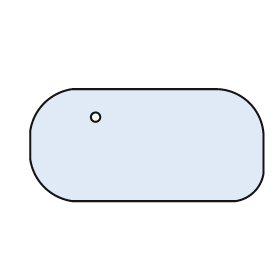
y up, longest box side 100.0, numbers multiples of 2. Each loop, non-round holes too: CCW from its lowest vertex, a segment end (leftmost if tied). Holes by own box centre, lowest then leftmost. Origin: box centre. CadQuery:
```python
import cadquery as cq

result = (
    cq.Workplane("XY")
    .moveTo(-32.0, -24.0)
    .lineTo(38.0, -24.0)
    .threePointArc((46.0, -20.0), (50.0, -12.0))
    .lineTo(50.0, 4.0)
    .threePointArc((44.0, 18.0), (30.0, 24.0))
    .lineTo(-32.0, 24.0)
    .threePointArc((-44.0, 18.0), (-50.0, 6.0))
    .lineTo(-50.0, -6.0)
    .threePointArc((-44.0, -18.0), (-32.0, -24.0))
    .close()
    .moveTo(-22.0, 12.0)
    .circle(2.0)
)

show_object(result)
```